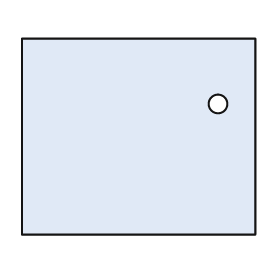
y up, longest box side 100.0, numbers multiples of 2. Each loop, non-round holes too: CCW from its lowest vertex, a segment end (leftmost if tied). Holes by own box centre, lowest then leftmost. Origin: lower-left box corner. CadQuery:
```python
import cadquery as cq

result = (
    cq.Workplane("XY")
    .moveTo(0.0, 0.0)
    .lineTo(100.0, 0.0)
    .lineTo(100.0, 84.0)
    .lineTo(0.0, 84.0)
    .close()
    .moveTo(84.0, 56.0)
    .circle(4.0)
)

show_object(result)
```